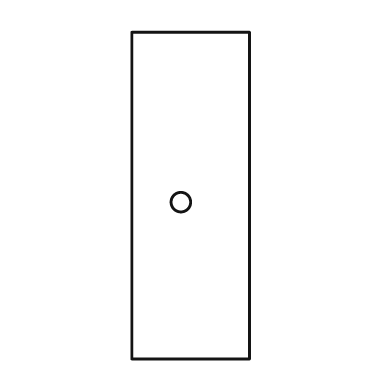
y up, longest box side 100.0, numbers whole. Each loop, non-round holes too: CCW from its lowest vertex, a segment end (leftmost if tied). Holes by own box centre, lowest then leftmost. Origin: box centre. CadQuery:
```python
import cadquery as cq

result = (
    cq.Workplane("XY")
    .moveTo(-18.0, -50.0)
    .lineTo(18.0, -50.0)
    .lineTo(18.0, 50.0)
    .lineTo(-18.0, 50.0)
    .close()
    .moveTo(-3.0, -2.0)
    .circle(3.0)
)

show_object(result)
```